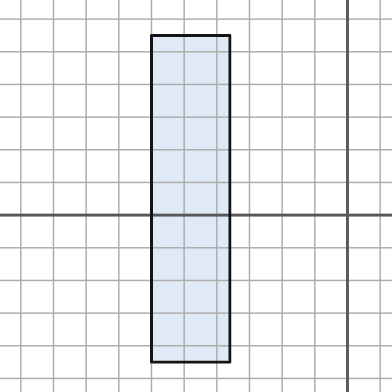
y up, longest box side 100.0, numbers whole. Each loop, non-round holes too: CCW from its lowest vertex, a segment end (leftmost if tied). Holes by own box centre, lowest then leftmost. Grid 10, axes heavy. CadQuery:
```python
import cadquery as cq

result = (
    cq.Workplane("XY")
    .moveTo(-60.0, -45.0)
    .lineTo(-36.0, -45.0)
    .lineTo(-36.0, 55.0)
    .lineTo(-60.0, 55.0)
    .close()
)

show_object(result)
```